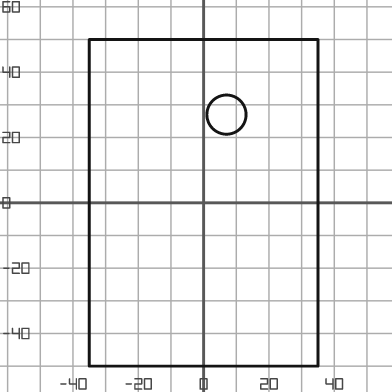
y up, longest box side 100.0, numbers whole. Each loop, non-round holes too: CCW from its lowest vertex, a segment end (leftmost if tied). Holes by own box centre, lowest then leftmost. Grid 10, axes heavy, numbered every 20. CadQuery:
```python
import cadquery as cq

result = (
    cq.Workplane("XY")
    .moveTo(-35.0, -50.0)
    .lineTo(35.0, -50.0)
    .lineTo(35.0, 50.0)
    .lineTo(-35.0, 50.0)
    .close()
    .moveTo(7.0, 27.0)
    .circle(6.0)
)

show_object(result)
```